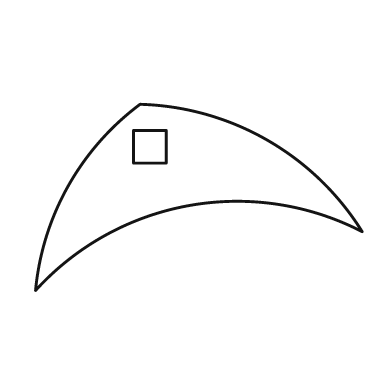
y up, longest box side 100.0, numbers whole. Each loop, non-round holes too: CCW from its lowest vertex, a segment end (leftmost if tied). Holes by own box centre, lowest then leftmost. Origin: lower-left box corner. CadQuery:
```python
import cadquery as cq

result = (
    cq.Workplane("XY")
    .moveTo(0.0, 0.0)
    .threePointArc((47.0, 26.0), (100.0, 18.0))
    .threePointArc((71.0, 46.0), (32.0, 57.0))
    .threePointArc((10.0, 32.0), (0.0, 0.0))
    .close()
    .moveTo(30.0, 39.0)
    .lineTo(40.0, 39.0)
    .lineTo(40.0, 49.0)
    .lineTo(30.0, 49.0)
    .close()
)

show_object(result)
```